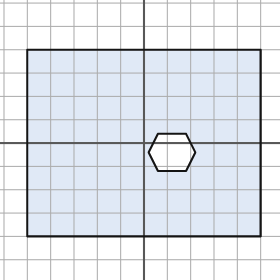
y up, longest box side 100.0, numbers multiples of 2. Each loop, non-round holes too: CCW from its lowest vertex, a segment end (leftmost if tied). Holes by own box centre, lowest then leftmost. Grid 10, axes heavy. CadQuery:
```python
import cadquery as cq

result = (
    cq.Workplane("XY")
    .moveTo(-50.0, -40.0)
    .lineTo(50.0, -40.0)
    .lineTo(50.0, 40.0)
    .lineTo(-50.0, 40.0)
    .close()
    .moveTo(6.0, -12.0)
    .lineTo(18.0, -12.0)
    .lineTo(22.0, -4.0)
    .lineTo(18.0, 4.0)
    .lineTo(6.0, 4.0)
    .lineTo(2.0, -4.0)
    .close()
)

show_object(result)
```